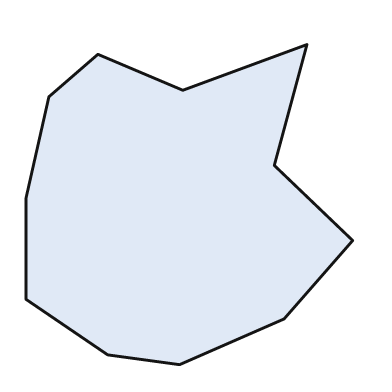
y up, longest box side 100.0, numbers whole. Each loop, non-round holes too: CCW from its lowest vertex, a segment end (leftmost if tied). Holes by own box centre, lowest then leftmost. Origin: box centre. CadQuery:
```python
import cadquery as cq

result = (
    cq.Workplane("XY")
    .moveTo(-3.0, -49.0)
    .lineTo(29.0, -35.0)
    .lineTo(50.0, -11.0)
    .lineTo(26.0, 12.0)
    .lineTo(36.0, 49.0)
    .lineTo(-2.0, 35.0)
    .lineTo(-28.0, 46.0)
    .lineTo(-43.0, 33.0)
    .lineTo(-50.0, 2.0)
    .lineTo(-50.0, -29.0)
    .lineTo(-25.0, -46.0)
    .close()
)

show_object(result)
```